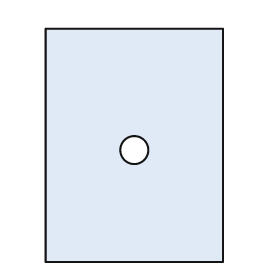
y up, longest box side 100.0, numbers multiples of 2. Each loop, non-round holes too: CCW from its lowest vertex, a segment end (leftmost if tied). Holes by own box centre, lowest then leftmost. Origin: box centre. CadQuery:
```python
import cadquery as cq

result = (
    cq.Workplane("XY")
    .moveTo(-38.0, -50.0)
    .lineTo(38.0, -50.0)
    .lineTo(38.0, 50.0)
    .lineTo(-38.0, 50.0)
    .close()
    .moveTo(0.0, -2.0)
    .circle(6.0)
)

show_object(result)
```